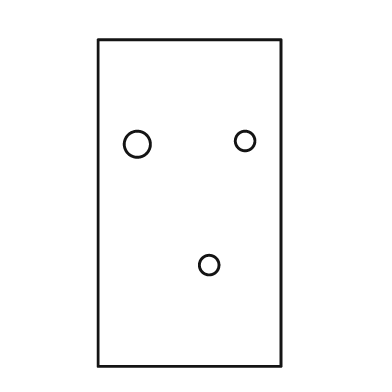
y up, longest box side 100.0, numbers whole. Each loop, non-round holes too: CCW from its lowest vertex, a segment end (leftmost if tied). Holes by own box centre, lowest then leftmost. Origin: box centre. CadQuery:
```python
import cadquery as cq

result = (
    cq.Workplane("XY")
    .moveTo(-28.0, -50.0)
    .lineTo(28.0, -50.0)
    .lineTo(28.0, 50.0)
    .lineTo(-28.0, 50.0)
    .close()
    .moveTo(6.0, -19.0)
    .circle(3.0)
    .moveTo(-16.0, 18.0)
    .circle(4.0)
    .moveTo(17.0, 19.0)
    .circle(3.0)
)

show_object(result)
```